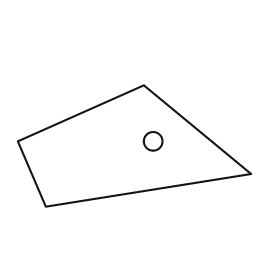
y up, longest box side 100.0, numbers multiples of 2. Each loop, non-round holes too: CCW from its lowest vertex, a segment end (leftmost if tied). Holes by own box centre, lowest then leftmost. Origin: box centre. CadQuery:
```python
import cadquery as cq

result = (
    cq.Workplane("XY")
    .moveTo(-38.0, -26.0)
    .lineTo(50.0, -12.0)
    .lineTo(4.0, 26.0)
    .lineTo(-50.0, 2.0)
    .close()
    .moveTo(8.0, 2.0)
    .circle(4.0)
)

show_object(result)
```